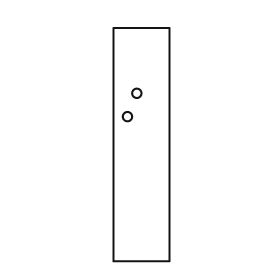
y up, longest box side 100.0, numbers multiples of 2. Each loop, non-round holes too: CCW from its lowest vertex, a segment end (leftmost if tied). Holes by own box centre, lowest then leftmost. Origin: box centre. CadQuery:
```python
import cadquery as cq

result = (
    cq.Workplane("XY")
    .moveTo(-12.0, -50.0)
    .lineTo(12.0, -50.0)
    .lineTo(12.0, 50.0)
    .lineTo(-12.0, 50.0)
    .close()
    .moveTo(-6.0, 12.0)
    .circle(2.0)
    .moveTo(-2.0, 22.0)
    .circle(2.0)
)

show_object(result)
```